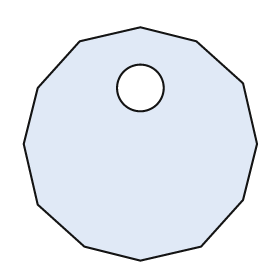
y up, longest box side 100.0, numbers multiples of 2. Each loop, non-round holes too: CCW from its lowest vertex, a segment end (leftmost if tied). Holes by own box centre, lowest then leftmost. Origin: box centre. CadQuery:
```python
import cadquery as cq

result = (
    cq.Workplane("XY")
    .moveTo(0.0, -50.0)
    .lineTo(26.0, -44.0)
    .lineTo(44.0, -24.0)
    .lineTo(50.0, 0.0)
    .lineTo(44.0, 26.0)
    .lineTo(24.0, 44.0)
    .lineTo(0.0, 50.0)
    .lineTo(-26.0, 44.0)
    .lineTo(-44.0, 24.0)
    .lineTo(-50.0, 0.0)
    .lineTo(-44.0, -26.0)
    .lineTo(-24.0, -44.0)
    .close()
    .moveTo(0.0, 24.0)
    .circle(10.0)
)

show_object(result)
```